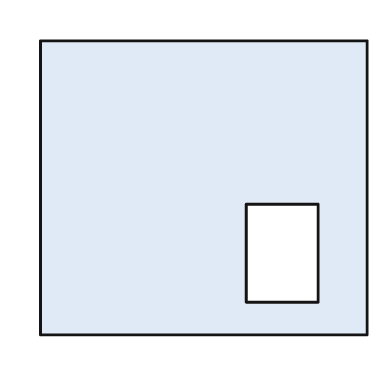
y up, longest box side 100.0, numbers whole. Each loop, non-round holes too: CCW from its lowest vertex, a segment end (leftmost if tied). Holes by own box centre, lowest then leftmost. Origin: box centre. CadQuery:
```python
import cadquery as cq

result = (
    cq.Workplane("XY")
    .moveTo(-50.0, -45.0)
    .lineTo(50.0, -45.0)
    .lineTo(50.0, 45.0)
    .lineTo(-50.0, 45.0)
    .close()
    .moveTo(13.0, -35.0)
    .lineTo(35.0, -35.0)
    .lineTo(35.0, -5.0)
    .lineTo(13.0, -5.0)
    .close()
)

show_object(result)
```